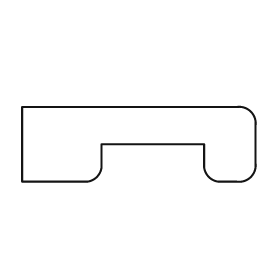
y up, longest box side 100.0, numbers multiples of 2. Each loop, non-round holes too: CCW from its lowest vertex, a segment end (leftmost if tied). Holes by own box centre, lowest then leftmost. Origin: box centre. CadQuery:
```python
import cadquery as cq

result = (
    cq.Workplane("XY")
    .moveTo(-50.0, -16.0)
    .lineTo(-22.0, -16.0)
    .threePointArc((-18.0, -14.0), (-16.0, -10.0))
    .lineTo(-16.0, 0.0)
    .lineTo(28.0, 0.0)
    .lineTo(28.0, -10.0)
    .threePointArc((30.0, -14.0), (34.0, -16.0))
    .lineTo(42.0, -16.0)
    .threePointArc((48.0, -14.0), (50.0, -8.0))
    .lineTo(50.0, 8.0)
    .threePointArc((48.0, 14.0), (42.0, 16.0))
    .lineTo(-50.0, 16.0)
    .close()
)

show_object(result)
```